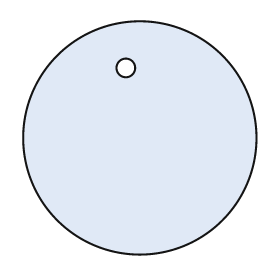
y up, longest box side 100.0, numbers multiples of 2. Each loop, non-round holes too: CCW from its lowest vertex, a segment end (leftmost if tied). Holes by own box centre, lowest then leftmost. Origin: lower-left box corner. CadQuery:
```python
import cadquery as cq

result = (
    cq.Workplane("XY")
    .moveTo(50.0, 50.0)
    .circle(50.0)
    .moveTo(44.0, 80.0)
    .circle(4.0)
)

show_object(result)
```